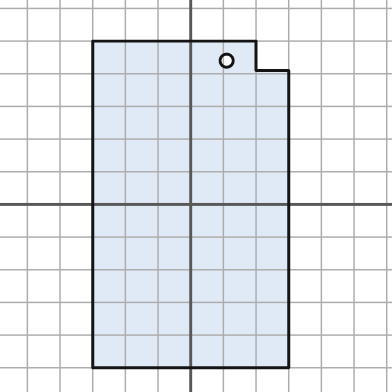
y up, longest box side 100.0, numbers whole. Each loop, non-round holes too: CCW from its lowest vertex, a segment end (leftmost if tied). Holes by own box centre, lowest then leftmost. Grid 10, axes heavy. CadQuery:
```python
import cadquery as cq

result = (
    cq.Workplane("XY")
    .moveTo(-30.0, -50.0)
    .lineTo(30.0, -50.0)
    .lineTo(30.0, 41.0)
    .lineTo(20.0, 41.0)
    .lineTo(20.0, 50.0)
    .lineTo(-30.0, 50.0)
    .close()
    .moveTo(11.0, 44.0)
    .circle(2.0)
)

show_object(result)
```